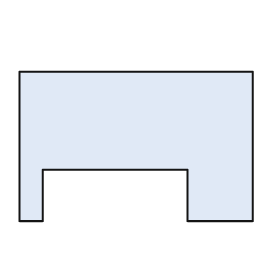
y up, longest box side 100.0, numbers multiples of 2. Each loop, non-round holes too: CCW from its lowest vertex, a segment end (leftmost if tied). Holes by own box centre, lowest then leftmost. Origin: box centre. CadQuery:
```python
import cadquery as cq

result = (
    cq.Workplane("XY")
    .moveTo(-50.0, -32.0)
    .lineTo(-40.0, -32.0)
    .lineTo(-40.0, -10.0)
    .lineTo(22.0, -10.0)
    .lineTo(22.0, -32.0)
    .lineTo(50.0, -32.0)
    .lineTo(50.0, 32.0)
    .lineTo(-50.0, 32.0)
    .close()
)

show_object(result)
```